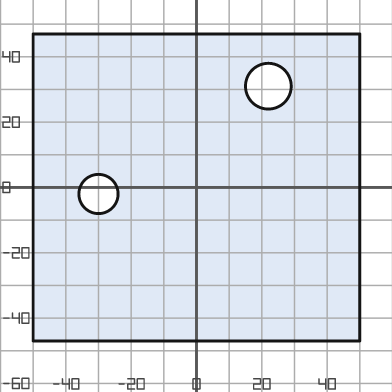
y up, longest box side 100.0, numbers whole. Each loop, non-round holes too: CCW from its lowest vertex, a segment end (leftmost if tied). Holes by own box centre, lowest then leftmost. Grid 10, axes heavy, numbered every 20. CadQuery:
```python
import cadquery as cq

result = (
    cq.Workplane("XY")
    .moveTo(-50.0, -47.0)
    .lineTo(50.0, -47.0)
    .lineTo(50.0, 47.0)
    .lineTo(-50.0, 47.0)
    .close()
    .moveTo(-30.0, -2.0)
    .circle(6.0)
    .moveTo(22.0, 31.0)
    .circle(7.0)
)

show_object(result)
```